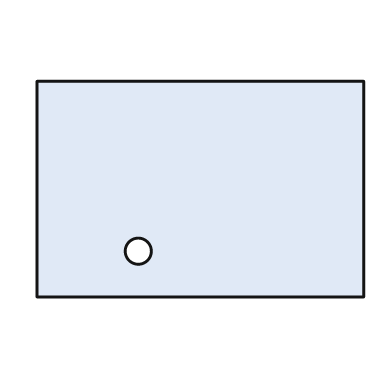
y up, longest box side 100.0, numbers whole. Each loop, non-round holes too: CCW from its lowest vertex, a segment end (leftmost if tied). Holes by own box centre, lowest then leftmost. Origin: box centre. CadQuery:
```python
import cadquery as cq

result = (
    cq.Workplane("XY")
    .moveTo(-50.0, -33.0)
    .lineTo(50.0, -33.0)
    .lineTo(50.0, 33.0)
    .lineTo(-50.0, 33.0)
    .close()
    .moveTo(-19.0, -19.0)
    .circle(4.0)
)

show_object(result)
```